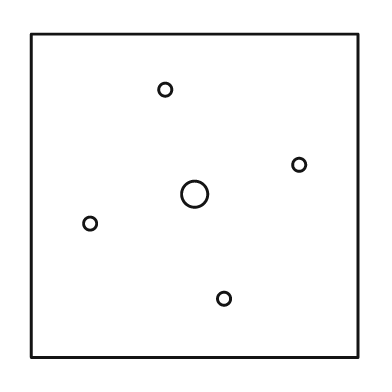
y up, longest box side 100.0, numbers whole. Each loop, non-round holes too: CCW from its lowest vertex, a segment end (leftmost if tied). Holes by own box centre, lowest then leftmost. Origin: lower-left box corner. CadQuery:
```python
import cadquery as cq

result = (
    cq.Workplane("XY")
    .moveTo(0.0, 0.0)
    .lineTo(100.0, 0.0)
    .lineTo(100.0, 99.0)
    .lineTo(0.0, 99.0)
    .close()
    .moveTo(59.0, 18.0)
    .circle(2.0)
    .moveTo(18.0, 41.0)
    .circle(2.0)
    .moveTo(50.0, 50.0)
    .circle(4.0)
    .moveTo(82.0, 59.0)
    .circle(2.0)
    .moveTo(41.0, 82.0)
    .circle(2.0)
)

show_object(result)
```